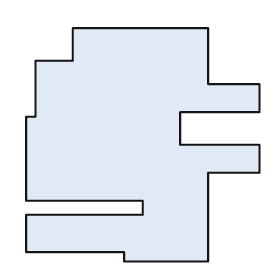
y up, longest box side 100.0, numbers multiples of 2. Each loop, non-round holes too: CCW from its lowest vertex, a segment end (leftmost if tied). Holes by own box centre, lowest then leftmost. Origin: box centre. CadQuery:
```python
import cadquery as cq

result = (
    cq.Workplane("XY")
    .moveTo(-8.0, -50.0)
    .lineTo(28.0, -50.0)
    .lineTo(28.0, -12.0)
    .lineTo(50.0, -12.0)
    .lineTo(50.0, 0.0)
    .lineTo(16.0, 0.0)
    .lineTo(16.0, 14.0)
    .lineTo(50.0, 14.0)
    .lineTo(50.0, 26.0)
    .lineTo(28.0, 26.0)
    .lineTo(28.0, 50.0)
    .lineTo(-30.0, 50.0)
    .lineTo(-30.0, 36.0)
    .lineTo(-46.0, 36.0)
    .lineTo(-46.0, 12.0)
    .lineTo(-50.0, 12.0)
    .lineTo(-50.0, -24.0)
    .lineTo(0.0, -24.0)
    .lineTo(0.0, -30.0)
    .lineTo(-50.0, -30.0)
    .lineTo(-50.0, -46.0)
    .lineTo(-8.0, -46.0)
    .close()
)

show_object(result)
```